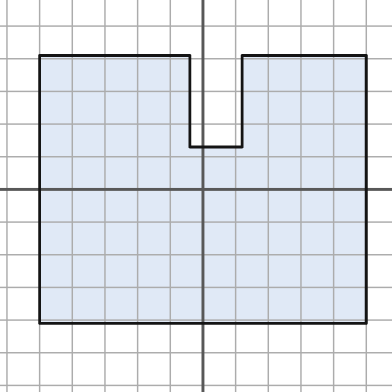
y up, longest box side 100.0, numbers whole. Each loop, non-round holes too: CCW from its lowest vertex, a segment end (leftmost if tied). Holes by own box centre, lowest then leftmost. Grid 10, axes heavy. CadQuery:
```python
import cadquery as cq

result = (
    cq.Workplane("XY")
    .moveTo(-50.0, -41.0)
    .lineTo(50.0, -41.0)
    .lineTo(50.0, 41.0)
    .lineTo(12.0, 41.0)
    .lineTo(12.0, 13.0)
    .lineTo(-4.0, 13.0)
    .lineTo(-4.0, 41.0)
    .lineTo(-50.0, 41.0)
    .close()
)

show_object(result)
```